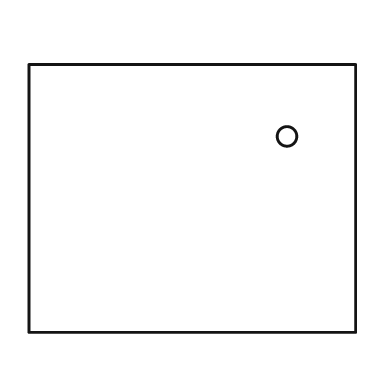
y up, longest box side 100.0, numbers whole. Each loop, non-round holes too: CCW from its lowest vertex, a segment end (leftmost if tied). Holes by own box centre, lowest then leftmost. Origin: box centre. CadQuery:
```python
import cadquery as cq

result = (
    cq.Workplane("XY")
    .moveTo(-50.0, -41.0)
    .lineTo(50.0, -41.0)
    .lineTo(50.0, 41.0)
    .lineTo(-50.0, 41.0)
    .close()
    .moveTo(29.0, 19.0)
    .circle(3.0)
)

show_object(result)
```